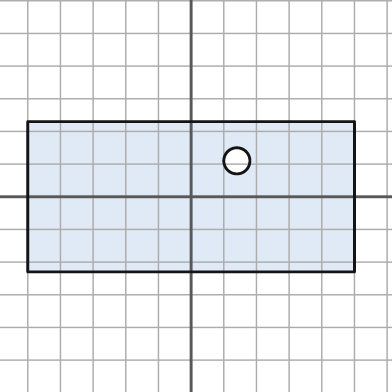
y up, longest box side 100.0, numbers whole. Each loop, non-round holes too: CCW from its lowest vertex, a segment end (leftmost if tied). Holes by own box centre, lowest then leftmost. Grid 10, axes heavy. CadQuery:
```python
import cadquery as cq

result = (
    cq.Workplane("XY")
    .moveTo(-50.0, -23.0)
    .lineTo(50.0, -23.0)
    .lineTo(50.0, 23.0)
    .lineTo(-50.0, 23.0)
    .close()
    .moveTo(14.0, 11.0)
    .circle(4.0)
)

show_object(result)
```